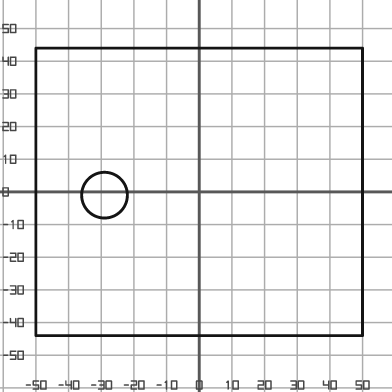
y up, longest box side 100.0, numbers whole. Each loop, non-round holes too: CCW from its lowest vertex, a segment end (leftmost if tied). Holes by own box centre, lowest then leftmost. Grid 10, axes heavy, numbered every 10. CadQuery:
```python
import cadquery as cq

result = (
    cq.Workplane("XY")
    .moveTo(-50.0, -44.0)
    .lineTo(50.0, -44.0)
    .lineTo(50.0, 44.0)
    .lineTo(-50.0, 44.0)
    .close()
    .moveTo(-29.0, -1.0)
    .circle(7.0)
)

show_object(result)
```